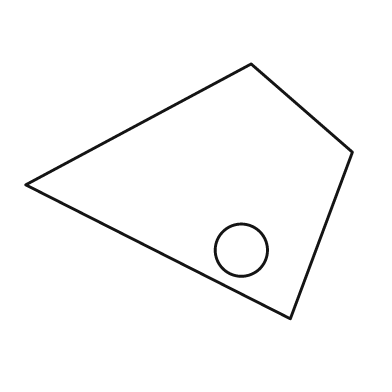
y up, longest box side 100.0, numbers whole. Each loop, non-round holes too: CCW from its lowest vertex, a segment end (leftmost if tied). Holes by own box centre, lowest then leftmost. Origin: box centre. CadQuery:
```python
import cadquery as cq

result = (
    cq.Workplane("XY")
    .moveTo(31.0, -39.0)
    .lineTo(50.0, 12.0)
    .lineTo(19.0, 39.0)
    .lineTo(-50.0, 2.0)
    .close()
    .moveTo(16.0, -18.0)
    .circle(8.0)
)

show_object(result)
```